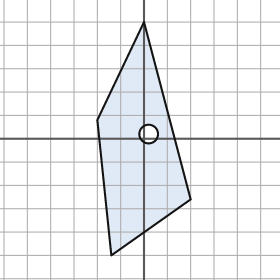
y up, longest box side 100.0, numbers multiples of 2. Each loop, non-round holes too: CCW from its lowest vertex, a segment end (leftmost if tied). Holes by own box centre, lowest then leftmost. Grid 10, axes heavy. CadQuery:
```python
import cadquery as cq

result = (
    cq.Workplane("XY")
    .moveTo(-14.0, -50.0)
    .lineTo(20.0, -26.0)
    .lineTo(0.0, 50.0)
    .lineTo(-20.0, 8.0)
    .close()
    .moveTo(2.0, 2.0)
    .circle(4.0)
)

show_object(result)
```